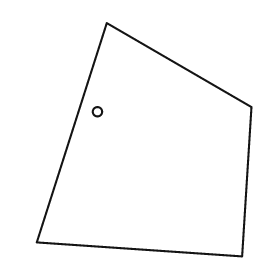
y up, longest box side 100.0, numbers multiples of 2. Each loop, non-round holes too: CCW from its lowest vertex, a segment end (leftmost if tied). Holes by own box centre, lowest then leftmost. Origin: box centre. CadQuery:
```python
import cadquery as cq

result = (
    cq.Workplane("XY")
    .moveTo(42.0, -50.0)
    .lineTo(46.0, 14.0)
    .lineTo(-16.0, 50.0)
    .lineTo(-46.0, -44.0)
    .close()
    .moveTo(-20.0, 12.0)
    .circle(2.0)
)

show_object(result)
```